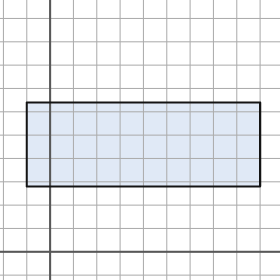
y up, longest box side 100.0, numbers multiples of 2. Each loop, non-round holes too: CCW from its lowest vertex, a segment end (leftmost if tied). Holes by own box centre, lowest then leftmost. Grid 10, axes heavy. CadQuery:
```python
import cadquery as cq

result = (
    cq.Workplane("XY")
    .moveTo(-10.0, 28.0)
    .lineTo(90.0, 28.0)
    .lineTo(90.0, 64.0)
    .lineTo(-10.0, 64.0)
    .close()
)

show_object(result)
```